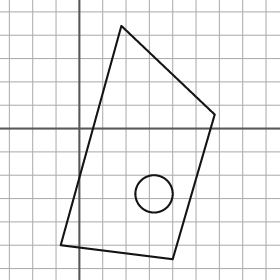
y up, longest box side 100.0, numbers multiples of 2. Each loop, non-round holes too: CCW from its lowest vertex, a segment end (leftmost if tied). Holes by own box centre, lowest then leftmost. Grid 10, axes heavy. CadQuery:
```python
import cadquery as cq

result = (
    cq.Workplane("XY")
    .moveTo(40.0, -56.0)
    .lineTo(58.0, 6.0)
    .lineTo(18.0, 44.0)
    .lineTo(-8.0, -50.0)
    .close()
    .moveTo(32.0, -28.0)
    .circle(8.0)
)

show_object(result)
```